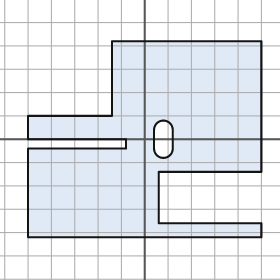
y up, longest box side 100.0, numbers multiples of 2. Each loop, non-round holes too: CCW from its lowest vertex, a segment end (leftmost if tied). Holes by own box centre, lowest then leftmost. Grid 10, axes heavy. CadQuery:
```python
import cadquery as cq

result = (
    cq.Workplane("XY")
    .moveTo(-50.0, -42.0)
    .lineTo(50.0, -42.0)
    .lineTo(50.0, -36.0)
    .lineTo(6.0, -36.0)
    .lineTo(6.0, -14.0)
    .lineTo(50.0, -14.0)
    .lineTo(50.0, 42.0)
    .lineTo(-14.0, 42.0)
    .lineTo(-14.0, 10.0)
    .lineTo(-50.0, 10.0)
    .lineTo(-50.0, 0.0)
    .lineTo(-8.0, 0.0)
    .lineTo(-8.0, -4.0)
    .lineTo(-50.0, -4.0)
    .close()
    .moveTo(4.0, -4.0)
    .threePointArc((8.0, -8.0), (12.0, -4.0))
    .lineTo(12.0, 4.0)
    .threePointArc((8.0, 8.0), (4.0, 4.0))
    .close()
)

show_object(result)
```